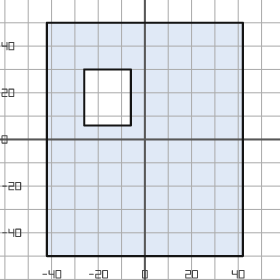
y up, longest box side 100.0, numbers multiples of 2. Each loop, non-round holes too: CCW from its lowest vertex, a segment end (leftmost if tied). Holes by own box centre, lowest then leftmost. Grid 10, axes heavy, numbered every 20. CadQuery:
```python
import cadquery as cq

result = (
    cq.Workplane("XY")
    .moveTo(-42.0, -50.0)
    .lineTo(42.0, -50.0)
    .lineTo(42.0, 50.0)
    .lineTo(-42.0, 50.0)
    .close()
    .moveTo(-26.0, 6.0)
    .lineTo(-6.0, 6.0)
    .lineTo(-6.0, 30.0)
    .lineTo(-26.0, 30.0)
    .close()
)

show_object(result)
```